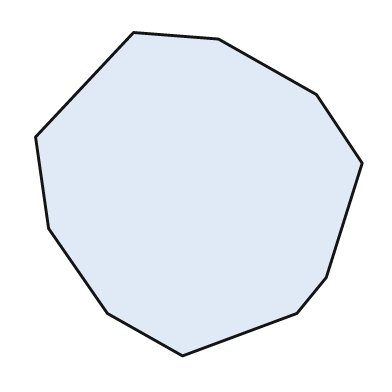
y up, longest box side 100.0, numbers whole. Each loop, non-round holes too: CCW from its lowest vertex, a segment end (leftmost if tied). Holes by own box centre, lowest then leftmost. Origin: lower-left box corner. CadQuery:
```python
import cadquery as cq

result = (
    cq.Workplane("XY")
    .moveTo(45.0, 0.0)
    .lineTo(80.0, 13.0)
    .lineTo(89.0, 24.0)
    .lineTo(100.0, 59.0)
    .lineTo(86.0, 80.0)
    .lineTo(56.0, 97.0)
    .lineTo(30.0, 99.0)
    .lineTo(0.0, 67.0)
    .lineTo(4.0, 39.0)
    .lineTo(22.0, 13.0)
    .close()
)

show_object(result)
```